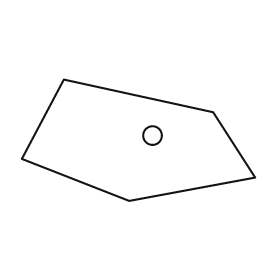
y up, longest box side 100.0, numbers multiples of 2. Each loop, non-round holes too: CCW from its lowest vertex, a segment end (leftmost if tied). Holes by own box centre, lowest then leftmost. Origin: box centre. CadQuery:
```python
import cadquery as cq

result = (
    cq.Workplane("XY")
    .moveTo(-4.0, -26.0)
    .lineTo(50.0, -16.0)
    .lineTo(32.0, 12.0)
    .lineTo(-32.0, 26.0)
    .lineTo(-50.0, -8.0)
    .close()
    .moveTo(6.0, 2.0)
    .circle(4.0)
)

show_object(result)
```